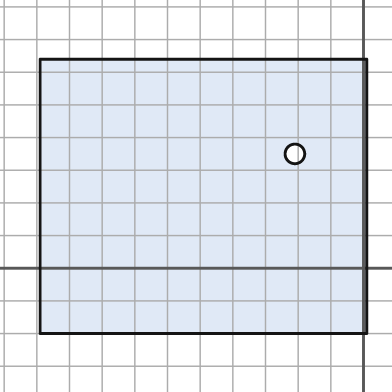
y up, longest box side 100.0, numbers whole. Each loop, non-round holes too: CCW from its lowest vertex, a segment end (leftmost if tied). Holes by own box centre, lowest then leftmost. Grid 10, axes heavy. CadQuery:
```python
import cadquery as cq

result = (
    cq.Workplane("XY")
    .moveTo(-99.0, -20.0)
    .lineTo(1.0, -20.0)
    .lineTo(1.0, 64.0)
    .lineTo(-99.0, 64.0)
    .close()
    .moveTo(-21.0, 35.0)
    .circle(3.0)
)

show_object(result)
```